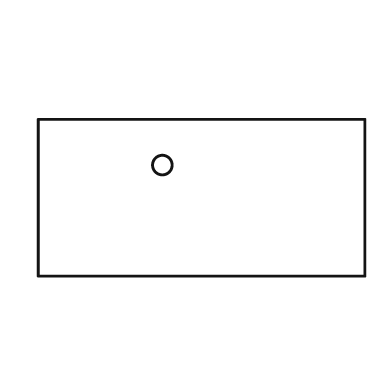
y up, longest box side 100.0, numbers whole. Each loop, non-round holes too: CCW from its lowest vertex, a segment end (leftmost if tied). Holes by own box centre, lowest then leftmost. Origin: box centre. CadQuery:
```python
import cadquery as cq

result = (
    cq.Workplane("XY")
    .moveTo(-50.0, -24.0)
    .lineTo(50.0, -24.0)
    .lineTo(50.0, 24.0)
    .lineTo(-50.0, 24.0)
    .close()
    .moveTo(-12.0, 10.0)
    .circle(3.0)
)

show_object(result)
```